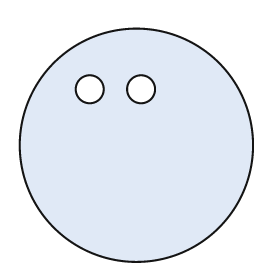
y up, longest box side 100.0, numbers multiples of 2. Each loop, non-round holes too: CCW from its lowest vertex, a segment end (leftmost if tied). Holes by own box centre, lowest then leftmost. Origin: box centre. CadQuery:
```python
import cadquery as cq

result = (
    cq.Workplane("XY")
    .moveTo(0.0, 0.0)
    .circle(50.0)
    .moveTo(-20.0, 24.0)
    .circle(6.0)
    .moveTo(2.0, 24.0)
    .circle(6.0)
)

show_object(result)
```